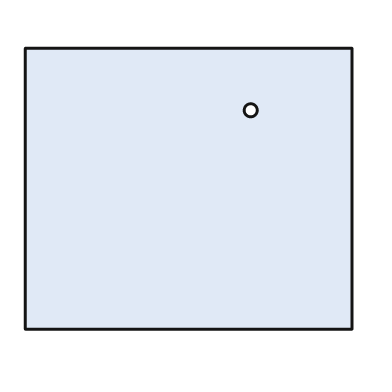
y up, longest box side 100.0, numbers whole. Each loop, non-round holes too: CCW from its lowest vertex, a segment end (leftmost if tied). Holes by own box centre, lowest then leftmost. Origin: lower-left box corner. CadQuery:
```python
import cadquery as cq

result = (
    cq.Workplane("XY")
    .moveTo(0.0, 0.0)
    .lineTo(100.0, 0.0)
    .lineTo(100.0, 86.0)
    .lineTo(0.0, 86.0)
    .close()
    .moveTo(69.0, 67.0)
    .circle(2.0)
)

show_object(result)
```